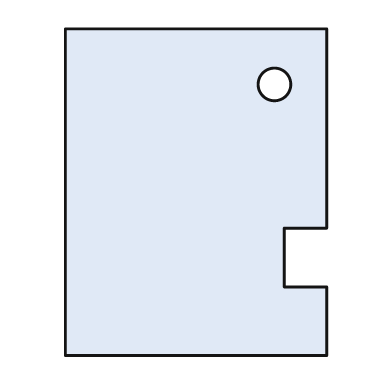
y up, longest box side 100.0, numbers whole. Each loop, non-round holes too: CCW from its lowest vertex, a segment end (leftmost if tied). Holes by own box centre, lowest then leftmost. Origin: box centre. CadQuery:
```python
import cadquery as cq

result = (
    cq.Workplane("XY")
    .moveTo(-40.0, -50.0)
    .lineTo(40.0, -50.0)
    .lineTo(40.0, -29.0)
    .lineTo(27.0, -29.0)
    .lineTo(27.0, -11.0)
    .lineTo(40.0, -11.0)
    .lineTo(40.0, 50.0)
    .lineTo(-40.0, 50.0)
    .close()
    .moveTo(24.0, 33.0)
    .circle(5.0)
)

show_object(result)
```